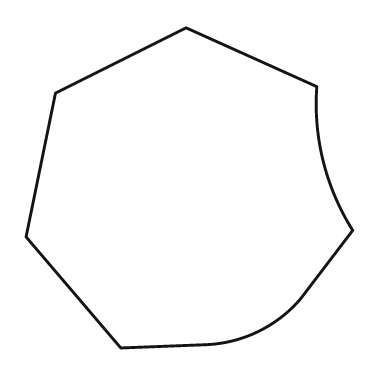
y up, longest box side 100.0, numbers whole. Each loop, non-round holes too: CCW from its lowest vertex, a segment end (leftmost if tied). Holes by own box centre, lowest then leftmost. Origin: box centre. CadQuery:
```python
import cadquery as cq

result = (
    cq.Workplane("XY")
    .moveTo(-21.0, -49.0)
    .lineTo(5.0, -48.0)
    .threePointArc((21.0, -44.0), (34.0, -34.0))
    .lineTo(50.0, -13.0)
    .threePointArc((41.0, 8.0), (39.0, 31.0))
    .lineTo(-1.0, 49.0)
    .lineTo(-41.0, 29.0)
    .lineTo(-50.0, -15.0)
    .close()
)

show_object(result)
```